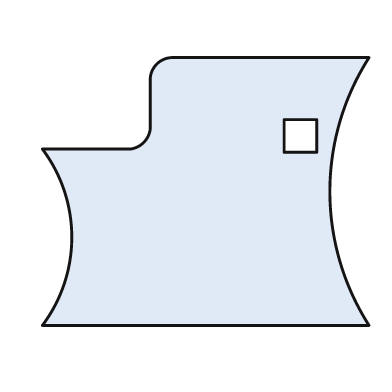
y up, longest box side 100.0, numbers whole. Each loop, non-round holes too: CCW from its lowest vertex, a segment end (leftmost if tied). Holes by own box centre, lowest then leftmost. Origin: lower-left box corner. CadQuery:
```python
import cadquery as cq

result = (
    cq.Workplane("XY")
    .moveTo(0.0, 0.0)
    .lineTo(100.0, 0.0)
    .threePointArc((88.0, 41.0), (100.0, 82.0))
    .lineTo(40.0, 82.0)
    .threePointArc((35.0, 80.0), (33.0, 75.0))
    .lineTo(33.0, 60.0)
    .threePointArc((31.0, 56.0), (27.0, 54.0))
    .lineTo(0.0, 54.0)
    .threePointArc((9.0, 27.0), (0.0, 0.0))
    .close()
    .moveTo(74.0, 53.0)
    .lineTo(84.0, 53.0)
    .lineTo(84.0, 63.0)
    .lineTo(74.0, 63.0)
    .close()
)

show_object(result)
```